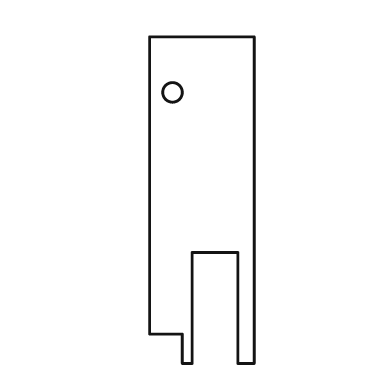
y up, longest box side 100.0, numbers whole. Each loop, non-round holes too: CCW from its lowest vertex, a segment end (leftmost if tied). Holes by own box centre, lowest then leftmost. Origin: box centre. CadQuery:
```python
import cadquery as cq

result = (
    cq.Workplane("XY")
    .moveTo(-6.0, -50.0)
    .lineTo(-3.0, -50.0)
    .lineTo(-3.0, -16.0)
    .lineTo(11.0, -16.0)
    .lineTo(11.0, -50.0)
    .lineTo(16.0, -50.0)
    .lineTo(16.0, 50.0)
    .lineTo(-16.0, 50.0)
    .lineTo(-16.0, -41.0)
    .lineTo(-6.0, -41.0)
    .close()
    .moveTo(-9.0, 33.0)
    .circle(3.0)
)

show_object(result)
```